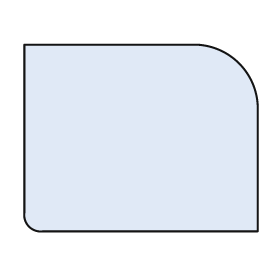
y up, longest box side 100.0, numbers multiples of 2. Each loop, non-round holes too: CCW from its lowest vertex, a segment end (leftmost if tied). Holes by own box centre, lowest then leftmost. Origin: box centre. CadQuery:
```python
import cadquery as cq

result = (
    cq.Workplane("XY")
    .moveTo(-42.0, -40.0)
    .lineTo(50.0, -40.0)
    .lineTo(50.0, 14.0)
    .threePointArc((42.0, 32.0), (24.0, 40.0))
    .lineTo(-50.0, 40.0)
    .lineTo(-50.0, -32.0)
    .threePointArc((-48.0, -38.0), (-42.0, -40.0))
    .close()
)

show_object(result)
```